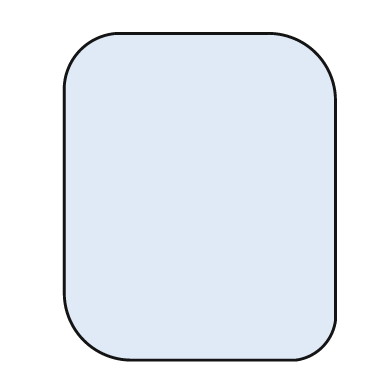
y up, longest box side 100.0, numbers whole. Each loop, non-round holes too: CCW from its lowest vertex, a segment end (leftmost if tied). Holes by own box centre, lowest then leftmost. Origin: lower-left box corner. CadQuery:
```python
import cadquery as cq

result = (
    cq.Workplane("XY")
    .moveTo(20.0, 0.0)
    .lineTo(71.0, 0.0)
    .threePointArc((79.0, 4.0), (83.0, 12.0))
    .lineTo(83.0, 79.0)
    .threePointArc((77.0, 94.0), (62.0, 100.0))
    .lineTo(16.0, 100.0)
    .threePointArc((5.0, 95.0), (0.0, 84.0))
    .lineTo(0.0, 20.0)
    .threePointArc((6.0, 6.0), (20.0, 0.0))
    .close()
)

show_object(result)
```